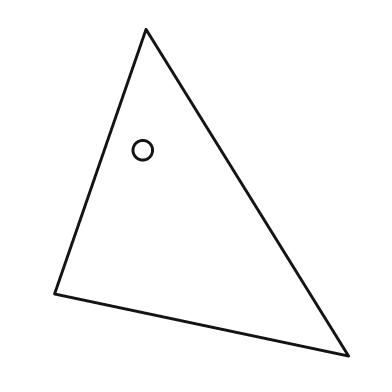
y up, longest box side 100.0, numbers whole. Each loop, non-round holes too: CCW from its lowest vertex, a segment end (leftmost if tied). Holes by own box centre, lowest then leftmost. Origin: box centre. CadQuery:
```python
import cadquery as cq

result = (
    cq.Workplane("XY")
    .moveTo(45.0, -50.0)
    .lineTo(-17.0, 50.0)
    .lineTo(-45.0, -31.0)
    .close()
    .moveTo(-18.0, 13.0)
    .circle(3.0)
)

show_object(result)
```